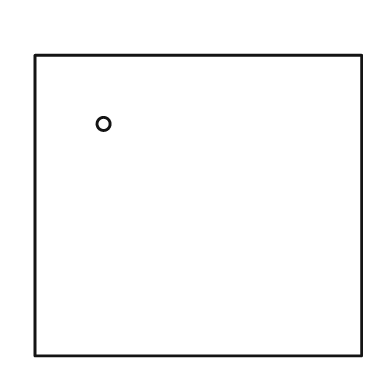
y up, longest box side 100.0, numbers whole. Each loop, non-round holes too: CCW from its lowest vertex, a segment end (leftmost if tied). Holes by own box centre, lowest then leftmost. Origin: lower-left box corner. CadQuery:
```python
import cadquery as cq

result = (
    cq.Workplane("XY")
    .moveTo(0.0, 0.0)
    .lineTo(100.0, 0.0)
    .lineTo(100.0, 92.0)
    .lineTo(0.0, 92.0)
    .close()
    .moveTo(21.0, 71.0)
    .circle(2.0)
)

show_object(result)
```